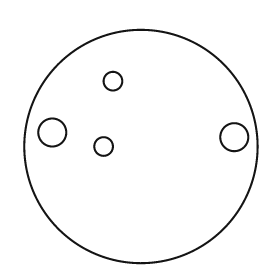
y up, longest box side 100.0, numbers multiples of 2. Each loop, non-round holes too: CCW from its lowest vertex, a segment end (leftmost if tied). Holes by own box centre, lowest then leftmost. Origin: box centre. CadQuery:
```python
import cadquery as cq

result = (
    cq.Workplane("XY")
    .moveTo(0.0, 0.0)
    .circle(50.0)
    .moveTo(-16.0, 0.0)
    .circle(4.0)
    .moveTo(40.0, 4.0)
    .circle(6.0)
    .moveTo(-38.0, 6.0)
    .circle(6.0)
    .moveTo(-12.0, 28.0)
    .circle(4.0)
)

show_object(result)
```